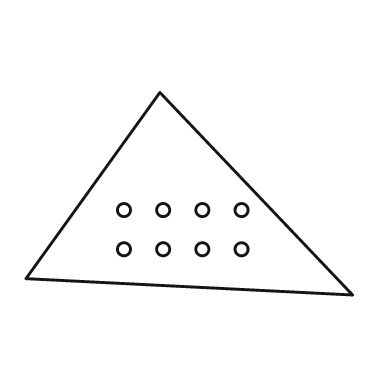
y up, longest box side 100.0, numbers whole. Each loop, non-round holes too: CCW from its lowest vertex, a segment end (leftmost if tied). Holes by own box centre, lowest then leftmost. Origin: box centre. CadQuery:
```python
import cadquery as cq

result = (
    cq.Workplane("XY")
    .moveTo(50.0, -31.0)
    .lineTo(-9.0, 31.0)
    .lineTo(-50.0, -26.0)
    .close()
    .moveTo(-20.0, -17.0)
    .circle(2.0)
    .moveTo(-8.0, -17.0)
    .circle(2.0)
    .moveTo(4.0, -17.0)
    .circle(2.0)
    .moveTo(16.0, -17.0)
    .circle(2.0)
    .moveTo(-20.0, -5.0)
    .circle(2.0)
    .moveTo(-8.0, -5.0)
    .circle(2.0)
    .moveTo(4.0, -5.0)
    .circle(2.0)
    .moveTo(16.0, -5.0)
    .circle(2.0)
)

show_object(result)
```